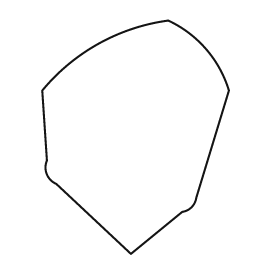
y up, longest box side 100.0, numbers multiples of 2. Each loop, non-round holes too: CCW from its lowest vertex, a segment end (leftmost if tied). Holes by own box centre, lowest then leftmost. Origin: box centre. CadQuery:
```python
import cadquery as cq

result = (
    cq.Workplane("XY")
    .moveTo(-2.0, -50.0)
    .lineTo(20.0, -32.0)
    .threePointArc((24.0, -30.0), (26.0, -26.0))
    .lineTo(40.0, 20.0)
    .threePointArc((30.0, 38.0), (14.0, 50.0))
    .threePointArc((-16.0, 40.0), (-40.0, 20.0))
    .lineTo(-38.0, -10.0)
    .threePointArc((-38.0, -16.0), (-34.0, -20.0))
    .close()
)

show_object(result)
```